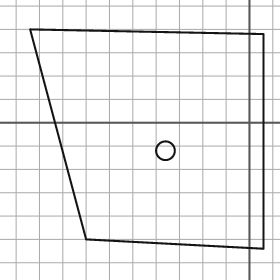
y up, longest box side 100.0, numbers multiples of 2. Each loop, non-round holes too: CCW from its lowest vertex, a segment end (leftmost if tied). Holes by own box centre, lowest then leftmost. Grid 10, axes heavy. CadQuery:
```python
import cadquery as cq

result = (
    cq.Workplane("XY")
    .moveTo(6.0, -54.0)
    .lineTo(6.0, 38.0)
    .lineTo(-94.0, 40.0)
    .lineTo(-70.0, -50.0)
    .close()
    .moveTo(-36.0, -12.0)
    .circle(4.0)
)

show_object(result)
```